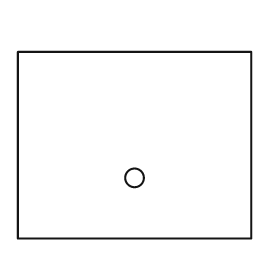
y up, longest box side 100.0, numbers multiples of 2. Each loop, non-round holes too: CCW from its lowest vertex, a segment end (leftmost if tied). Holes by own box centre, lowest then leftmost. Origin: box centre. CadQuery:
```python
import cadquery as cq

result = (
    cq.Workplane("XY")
    .moveTo(-50.0, -40.0)
    .lineTo(50.0, -40.0)
    .lineTo(50.0, 40.0)
    .lineTo(-50.0, 40.0)
    .close()
    .moveTo(0.0, -14.0)
    .circle(4.0)
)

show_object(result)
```